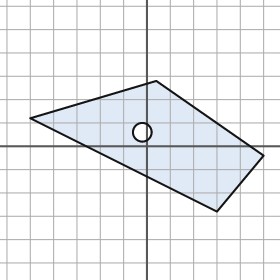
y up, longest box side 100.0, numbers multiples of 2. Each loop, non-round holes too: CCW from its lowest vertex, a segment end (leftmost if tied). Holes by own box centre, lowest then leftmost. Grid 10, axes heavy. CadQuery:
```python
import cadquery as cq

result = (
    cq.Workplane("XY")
    .moveTo(30.0, -28.0)
    .lineTo(50.0, -4.0)
    .lineTo(4.0, 28.0)
    .lineTo(-50.0, 12.0)
    .close()
    .moveTo(-2.0, 6.0)
    .circle(4.0)
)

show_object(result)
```